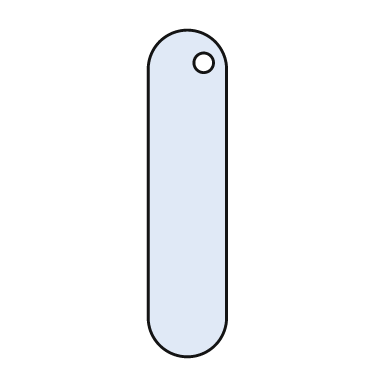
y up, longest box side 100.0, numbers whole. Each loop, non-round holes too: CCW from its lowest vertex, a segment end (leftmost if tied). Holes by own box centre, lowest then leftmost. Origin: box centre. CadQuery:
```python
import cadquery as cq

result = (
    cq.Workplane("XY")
    .moveTo(-12.0, -38.0)
    .threePointArc((0.0, -50.0), (12.0, -38.0))
    .lineTo(12.0, 38.0)
    .threePointArc((0.0, 50.0), (-12.0, 38.0))
    .close()
    .moveTo(5.0, 40.0)
    .circle(3.0)
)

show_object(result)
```